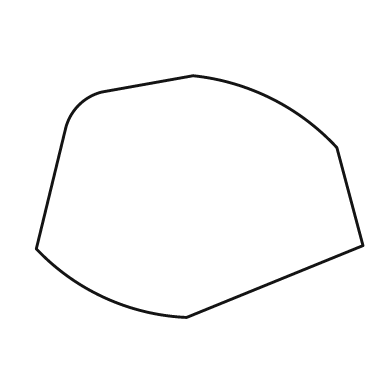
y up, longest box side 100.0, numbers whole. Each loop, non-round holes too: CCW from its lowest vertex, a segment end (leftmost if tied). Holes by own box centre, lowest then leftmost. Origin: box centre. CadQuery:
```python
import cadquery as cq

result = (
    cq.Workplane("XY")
    .moveTo(-4.0, -37.0)
    .lineTo(50.0, -15.0)
    .lineTo(42.0, 15.0)
    .threePointArc((22.0, 30.0), (-2.0, 37.0))
    .lineTo(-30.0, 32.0)
    .threePointArc((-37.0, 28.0), (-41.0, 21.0))
    .lineTo(-50.0, -16.0)
    .threePointArc((-29.0, -31.0), (-4.0, -37.0))
    .close()
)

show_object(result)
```